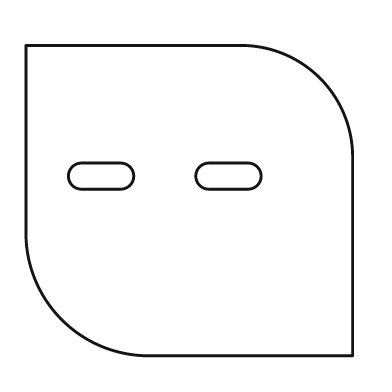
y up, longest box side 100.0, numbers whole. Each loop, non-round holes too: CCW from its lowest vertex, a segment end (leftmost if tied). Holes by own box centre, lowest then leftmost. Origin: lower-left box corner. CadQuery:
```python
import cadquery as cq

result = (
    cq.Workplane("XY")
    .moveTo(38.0, 0.0)
    .lineTo(100.0, 0.0)
    .lineTo(100.0, 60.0)
    .threePointArc((90.0, 85.0), (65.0, 95.0))
    .lineTo(0.0, 95.0)
    .lineTo(0.0, 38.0)
    .threePointArc((11.0, 11.0), (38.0, 0.0))
    .close()
    .moveTo(17.0, 51.0)
    .lineTo(29.0, 51.0)
    .threePointArc((33.0, 55.0), (29.0, 59.0))
    .lineTo(17.0, 59.0)
    .threePointArc((13.0, 55.0), (17.0, 51.0))
    .close()
    .moveTo(56.0, 51.0)
    .lineTo(68.0, 51.0)
    .threePointArc((72.0, 55.0), (68.0, 59.0))
    .lineTo(56.0, 59.0)
    .threePointArc((52.0, 55.0), (56.0, 51.0))
    .close()
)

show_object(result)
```